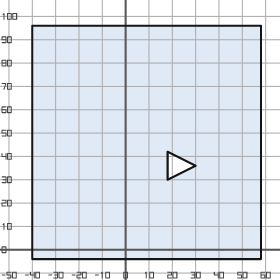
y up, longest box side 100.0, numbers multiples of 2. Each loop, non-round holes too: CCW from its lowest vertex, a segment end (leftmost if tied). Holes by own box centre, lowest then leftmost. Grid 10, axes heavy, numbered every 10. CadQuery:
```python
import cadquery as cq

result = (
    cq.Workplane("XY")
    .moveTo(-40.0, -4.0)
    .lineTo(58.0, -4.0)
    .lineTo(58.0, 96.0)
    .lineTo(-40.0, 96.0)
    .close()
    .moveTo(18.0, 30.0)
    .lineTo(30.0, 36.0)
    .lineTo(18.0, 42.0)
    .close()
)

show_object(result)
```